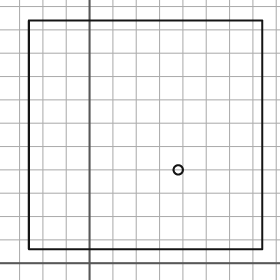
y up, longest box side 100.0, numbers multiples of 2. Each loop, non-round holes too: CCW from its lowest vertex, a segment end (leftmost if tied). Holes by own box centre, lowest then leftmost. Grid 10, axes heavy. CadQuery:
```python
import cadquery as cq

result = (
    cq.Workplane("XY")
    .moveTo(-26.0, 6.0)
    .lineTo(74.0, 6.0)
    .lineTo(74.0, 104.0)
    .lineTo(-26.0, 104.0)
    .close()
    .moveTo(38.0, 40.0)
    .circle(2.0)
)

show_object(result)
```